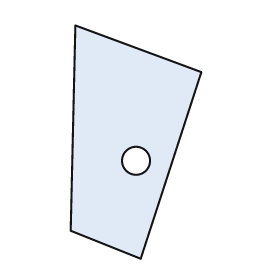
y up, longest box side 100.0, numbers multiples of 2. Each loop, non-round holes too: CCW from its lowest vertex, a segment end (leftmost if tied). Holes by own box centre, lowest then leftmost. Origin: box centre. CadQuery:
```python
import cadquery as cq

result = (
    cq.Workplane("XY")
    .moveTo(2.0, -50.0)
    .lineTo(28.0, 30.0)
    .lineTo(-26.0, 50.0)
    .lineTo(-28.0, -38.0)
    .close()
    .moveTo(0.0, -8.0)
    .circle(6.0)
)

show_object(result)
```